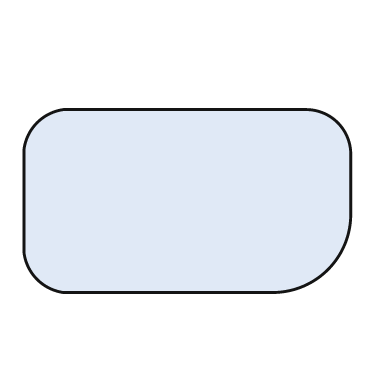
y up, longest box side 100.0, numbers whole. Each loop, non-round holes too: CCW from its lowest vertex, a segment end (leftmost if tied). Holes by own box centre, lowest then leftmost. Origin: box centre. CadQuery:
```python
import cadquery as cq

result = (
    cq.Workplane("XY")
    .moveTo(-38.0, -28.0)
    .lineTo(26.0, -28.0)
    .threePointArc((43.0, -21.0), (50.0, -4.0))
    .lineTo(50.0, 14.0)
    .threePointArc((46.0, 24.0), (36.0, 28.0))
    .lineTo(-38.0, 28.0)
    .threePointArc((-46.0, 24.0), (-50.0, 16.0))
    .lineTo(-50.0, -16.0)
    .threePointArc((-46.0, -24.0), (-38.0, -28.0))
    .close()
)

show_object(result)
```